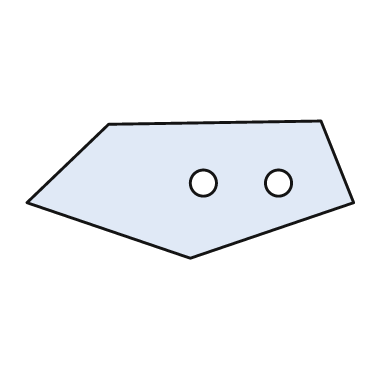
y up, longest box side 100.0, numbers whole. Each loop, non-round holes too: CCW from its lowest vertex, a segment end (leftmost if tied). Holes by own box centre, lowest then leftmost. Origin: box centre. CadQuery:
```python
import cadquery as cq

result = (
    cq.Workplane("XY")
    .moveTo(0.0, -21.0)
    .lineTo(50.0, -4.0)
    .lineTo(40.0, 21.0)
    .lineTo(-25.0, 20.0)
    .lineTo(-50.0, -4.0)
    .close()
    .moveTo(4.0, 2.0)
    .circle(4.0)
    .moveTo(27.0, 2.0)
    .circle(4.0)
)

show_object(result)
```